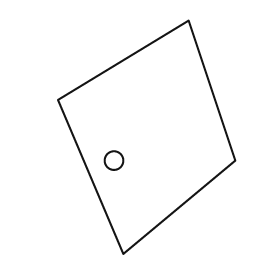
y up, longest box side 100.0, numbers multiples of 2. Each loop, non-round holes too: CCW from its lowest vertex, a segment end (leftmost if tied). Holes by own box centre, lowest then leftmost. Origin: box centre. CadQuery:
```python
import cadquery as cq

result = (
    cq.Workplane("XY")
    .moveTo(-10.0, -50.0)
    .lineTo(38.0, -10.0)
    .lineTo(18.0, 50.0)
    .lineTo(-38.0, 16.0)
    .close()
    .moveTo(-14.0, -10.0)
    .circle(4.0)
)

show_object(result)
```